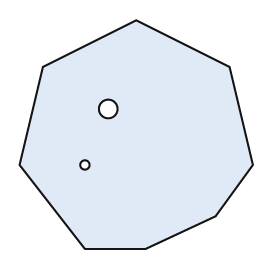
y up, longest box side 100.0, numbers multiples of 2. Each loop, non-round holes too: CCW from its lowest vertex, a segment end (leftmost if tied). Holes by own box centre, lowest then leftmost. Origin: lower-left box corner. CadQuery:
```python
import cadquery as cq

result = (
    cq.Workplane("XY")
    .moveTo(28.0, 0.0)
    .lineTo(54.0, 0.0)
    .lineTo(84.0, 14.0)
    .lineTo(100.0, 36.0)
    .lineTo(90.0, 78.0)
    .lineTo(50.0, 98.0)
    .lineTo(10.0, 78.0)
    .lineTo(0.0, 36.0)
    .close()
    .moveTo(28.0, 36.0)
    .circle(2.0)
    .moveTo(38.0, 60.0)
    .circle(4.0)
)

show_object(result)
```